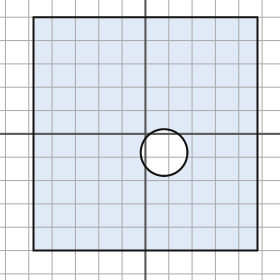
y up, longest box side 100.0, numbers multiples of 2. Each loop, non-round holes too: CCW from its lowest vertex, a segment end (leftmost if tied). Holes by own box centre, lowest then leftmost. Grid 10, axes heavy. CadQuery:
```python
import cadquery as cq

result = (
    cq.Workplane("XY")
    .moveTo(-48.0, -50.0)
    .lineTo(48.0, -50.0)
    .lineTo(48.0, 50.0)
    .lineTo(-48.0, 50.0)
    .close()
    .moveTo(8.0, -8.0)
    .circle(10.0)
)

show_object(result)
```